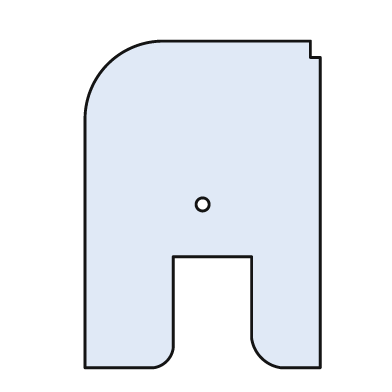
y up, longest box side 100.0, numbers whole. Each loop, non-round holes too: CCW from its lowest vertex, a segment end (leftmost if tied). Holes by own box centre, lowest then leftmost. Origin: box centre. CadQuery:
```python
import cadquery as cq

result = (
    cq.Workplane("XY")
    .moveTo(-36.0, -50.0)
    .lineTo(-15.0, -50.0)
    .threePointArc((-11.0, -48.0), (-9.0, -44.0))
    .lineTo(-9.0, -16.0)
    .lineTo(15.0, -16.0)
    .lineTo(15.0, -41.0)
    .threePointArc((18.0, -47.0), (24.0, -50.0))
    .lineTo(36.0, -50.0)
    .lineTo(36.0, 45.0)
    .lineTo(33.0, 45.0)
    .lineTo(33.0, 50.0)
    .lineTo(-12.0, 50.0)
    .threePointArc((-29.0, 43.0), (-36.0, 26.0))
    .close()
    .moveTo(0.0, 0.0)
    .circle(2.0)
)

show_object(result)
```